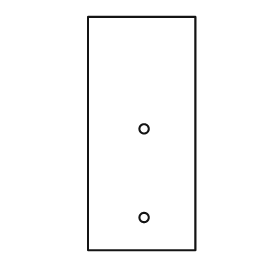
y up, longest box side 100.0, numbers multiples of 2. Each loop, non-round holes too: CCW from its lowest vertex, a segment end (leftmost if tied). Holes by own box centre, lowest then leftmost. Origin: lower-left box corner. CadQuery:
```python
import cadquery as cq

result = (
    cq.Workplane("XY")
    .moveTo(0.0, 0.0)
    .lineTo(46.0, 0.0)
    .lineTo(46.0, 100.0)
    .lineTo(0.0, 100.0)
    .close()
    .moveTo(24.0, 14.0)
    .circle(2.0)
    .moveTo(24.0, 52.0)
    .circle(2.0)
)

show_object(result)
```